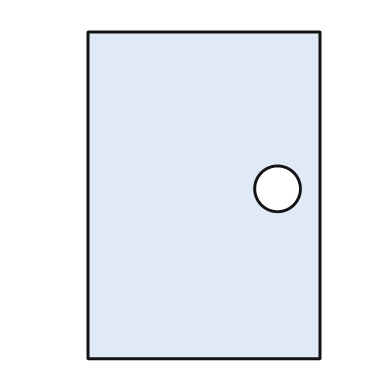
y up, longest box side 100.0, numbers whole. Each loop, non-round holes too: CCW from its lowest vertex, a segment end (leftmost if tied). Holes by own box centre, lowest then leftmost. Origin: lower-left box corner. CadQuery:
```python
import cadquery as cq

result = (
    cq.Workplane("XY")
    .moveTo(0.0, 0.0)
    .lineTo(71.0, 0.0)
    .lineTo(71.0, 100.0)
    .lineTo(0.0, 100.0)
    .close()
    .moveTo(58.0, 52.0)
    .circle(7.0)
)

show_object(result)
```